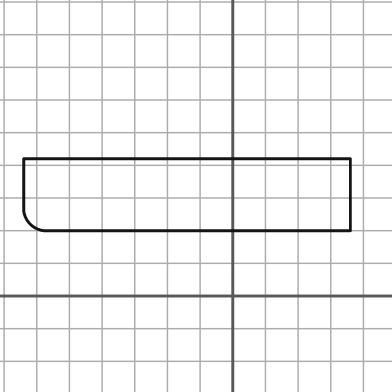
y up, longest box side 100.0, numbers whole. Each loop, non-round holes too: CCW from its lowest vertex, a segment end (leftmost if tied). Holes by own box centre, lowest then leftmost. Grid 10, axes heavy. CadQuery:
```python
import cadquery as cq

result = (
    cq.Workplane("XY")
    .moveTo(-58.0, 20.0)
    .lineTo(36.0, 20.0)
    .lineTo(36.0, 42.0)
    .lineTo(-64.0, 42.0)
    .lineTo(-64.0, 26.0)
    .threePointArc((-62.0, 22.0), (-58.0, 20.0))
    .close()
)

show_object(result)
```